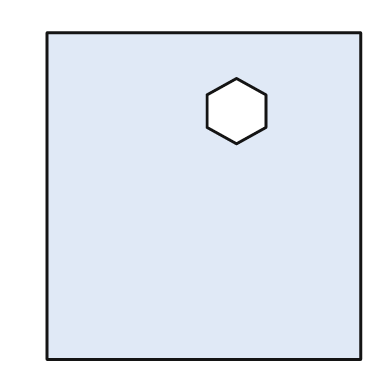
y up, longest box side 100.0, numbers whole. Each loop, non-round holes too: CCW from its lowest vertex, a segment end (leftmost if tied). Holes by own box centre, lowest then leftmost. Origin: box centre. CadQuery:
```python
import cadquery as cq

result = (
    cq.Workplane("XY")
    .moveTo(-48.0, -50.0)
    .lineTo(48.0, -50.0)
    .lineTo(48.0, 50.0)
    .lineTo(-48.0, 50.0)
    .close()
    .moveTo(10.0, 16.0)
    .lineTo(19.0, 21.0)
    .lineTo(19.0, 31.0)
    .lineTo(10.0, 36.0)
    .lineTo(1.0, 31.0)
    .lineTo(1.0, 21.0)
    .close()
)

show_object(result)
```